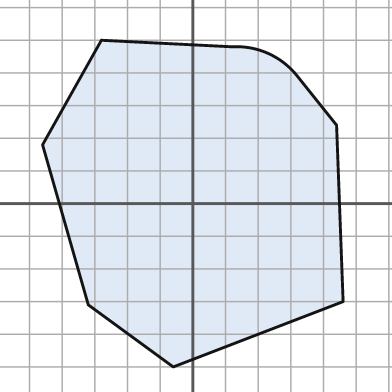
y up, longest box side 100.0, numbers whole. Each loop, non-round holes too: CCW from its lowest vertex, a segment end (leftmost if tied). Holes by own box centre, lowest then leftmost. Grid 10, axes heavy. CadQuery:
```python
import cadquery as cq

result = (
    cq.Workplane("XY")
    .moveTo(-6.0, -50.0)
    .lineTo(46.0, -30.0)
    .lineTo(44.0, 24.0)
    .lineTo(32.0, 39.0)
    .threePointArc((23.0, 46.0), (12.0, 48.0))
    .lineTo(-28.0, 50.0)
    .lineTo(-46.0, 18.0)
    .lineTo(-32.0, -31.0)
    .close()
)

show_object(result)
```